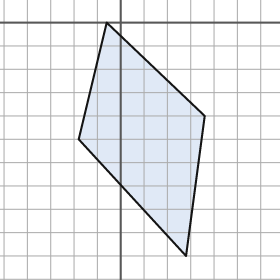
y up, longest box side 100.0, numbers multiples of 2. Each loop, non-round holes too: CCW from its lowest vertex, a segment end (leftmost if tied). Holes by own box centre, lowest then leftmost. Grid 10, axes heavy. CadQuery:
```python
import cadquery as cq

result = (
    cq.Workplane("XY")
    .moveTo(28.0, -100.0)
    .lineTo(36.0, -40.0)
    .lineTo(-6.0, 0.0)
    .lineTo(-18.0, -50.0)
    .close()
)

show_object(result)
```